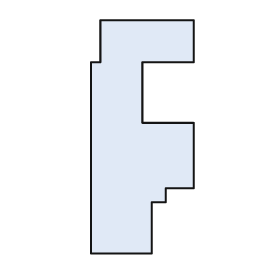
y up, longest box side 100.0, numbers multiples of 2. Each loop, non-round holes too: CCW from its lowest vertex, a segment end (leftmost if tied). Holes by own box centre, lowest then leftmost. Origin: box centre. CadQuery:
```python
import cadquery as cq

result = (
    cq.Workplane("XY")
    .moveTo(-22.0, -50.0)
    .lineTo(4.0, -50.0)
    .lineTo(4.0, -28.0)
    .lineTo(10.0, -28.0)
    .lineTo(10.0, -22.0)
    .lineTo(22.0, -22.0)
    .lineTo(22.0, 6.0)
    .lineTo(0.0, 6.0)
    .lineTo(0.0, 32.0)
    .lineTo(22.0, 32.0)
    .lineTo(22.0, 50.0)
    .lineTo(-18.0, 50.0)
    .lineTo(-18.0, 32.0)
    .lineTo(-22.0, 32.0)
    .close()
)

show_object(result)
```